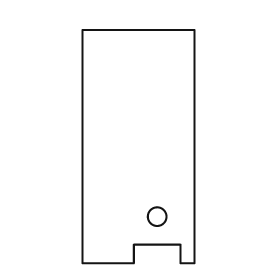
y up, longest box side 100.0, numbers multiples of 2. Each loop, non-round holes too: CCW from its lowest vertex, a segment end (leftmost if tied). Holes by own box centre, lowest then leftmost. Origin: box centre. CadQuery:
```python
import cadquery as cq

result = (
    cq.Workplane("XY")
    .moveTo(-24.0, -50.0)
    .lineTo(-2.0, -50.0)
    .lineTo(-2.0, -42.0)
    .lineTo(18.0, -42.0)
    .lineTo(18.0, -50.0)
    .lineTo(24.0, -50.0)
    .lineTo(24.0, 50.0)
    .lineTo(-24.0, 50.0)
    .close()
    .moveTo(8.0, -30.0)
    .circle(4.0)
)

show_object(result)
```